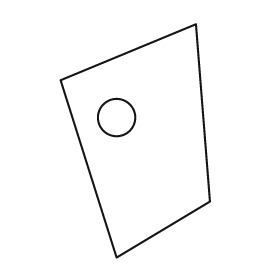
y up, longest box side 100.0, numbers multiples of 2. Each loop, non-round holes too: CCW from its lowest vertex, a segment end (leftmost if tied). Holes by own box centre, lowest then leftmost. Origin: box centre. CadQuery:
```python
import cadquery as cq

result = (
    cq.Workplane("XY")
    .moveTo(-8.0, -50.0)
    .lineTo(32.0, -26.0)
    .lineTo(26.0, 50.0)
    .lineTo(-32.0, 26.0)
    .close()
    .moveTo(-8.0, 10.0)
    .circle(8.0)
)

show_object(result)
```